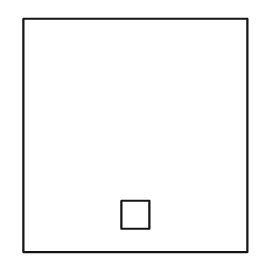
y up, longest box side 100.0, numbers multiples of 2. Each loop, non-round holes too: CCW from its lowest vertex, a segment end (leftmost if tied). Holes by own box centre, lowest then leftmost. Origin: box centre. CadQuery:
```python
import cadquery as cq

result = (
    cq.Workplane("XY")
    .moveTo(-48.0, -50.0)
    .lineTo(48.0, -50.0)
    .lineTo(48.0, 50.0)
    .lineTo(-48.0, 50.0)
    .close()
    .moveTo(-6.0, -40.0)
    .lineTo(6.0, -40.0)
    .lineTo(6.0, -28.0)
    .lineTo(-6.0, -28.0)
    .close()
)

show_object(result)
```